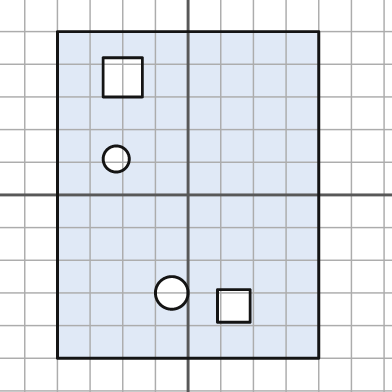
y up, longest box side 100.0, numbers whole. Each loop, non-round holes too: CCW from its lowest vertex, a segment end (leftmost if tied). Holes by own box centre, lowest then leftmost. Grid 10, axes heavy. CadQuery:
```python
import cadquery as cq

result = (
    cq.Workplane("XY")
    .moveTo(-40.0, -50.0)
    .lineTo(40.0, -50.0)
    .lineTo(40.0, 50.0)
    .lineTo(-40.0, 50.0)
    .close()
    .moveTo(9.0, -39.0)
    .lineTo(19.0, -39.0)
    .lineTo(19.0, -29.0)
    .lineTo(9.0, -29.0)
    .close()
    .moveTo(-5.0, -30.0)
    .circle(5.0)
    .moveTo(-22.0, 11.0)
    .circle(4.0)
    .moveTo(-26.0, 30.0)
    .lineTo(-14.0, 30.0)
    .lineTo(-14.0, 42.0)
    .lineTo(-26.0, 42.0)
    .close()
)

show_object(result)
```